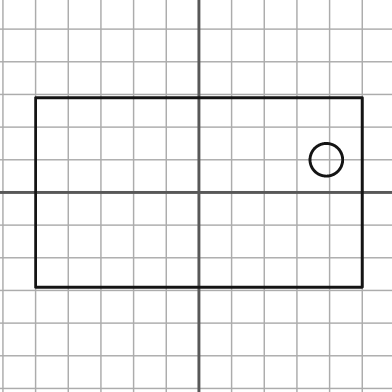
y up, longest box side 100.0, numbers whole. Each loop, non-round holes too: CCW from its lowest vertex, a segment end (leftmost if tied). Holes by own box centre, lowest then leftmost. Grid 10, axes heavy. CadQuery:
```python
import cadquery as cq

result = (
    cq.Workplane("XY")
    .moveTo(-50.0, -29.0)
    .lineTo(50.0, -29.0)
    .lineTo(50.0, 29.0)
    .lineTo(-50.0, 29.0)
    .close()
    .moveTo(39.0, 10.0)
    .circle(5.0)
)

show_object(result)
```